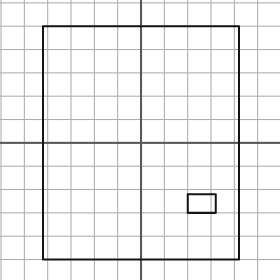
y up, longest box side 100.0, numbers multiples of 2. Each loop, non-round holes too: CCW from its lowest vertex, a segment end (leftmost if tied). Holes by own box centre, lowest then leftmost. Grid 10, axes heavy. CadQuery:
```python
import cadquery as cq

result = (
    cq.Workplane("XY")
    .moveTo(-42.0, -50.0)
    .lineTo(42.0, -50.0)
    .lineTo(42.0, 50.0)
    .lineTo(-42.0, 50.0)
    .close()
    .moveTo(20.0, -30.0)
    .lineTo(32.0, -30.0)
    .lineTo(32.0, -22.0)
    .lineTo(20.0, -22.0)
    .close()
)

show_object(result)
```